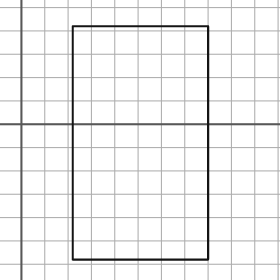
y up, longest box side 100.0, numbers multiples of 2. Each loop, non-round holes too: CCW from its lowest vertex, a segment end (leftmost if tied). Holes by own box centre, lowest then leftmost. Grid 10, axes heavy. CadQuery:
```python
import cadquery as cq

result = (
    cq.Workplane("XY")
    .moveTo(22.0, -58.0)
    .lineTo(80.0, -58.0)
    .lineTo(80.0, 42.0)
    .lineTo(22.0, 42.0)
    .close()
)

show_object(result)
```